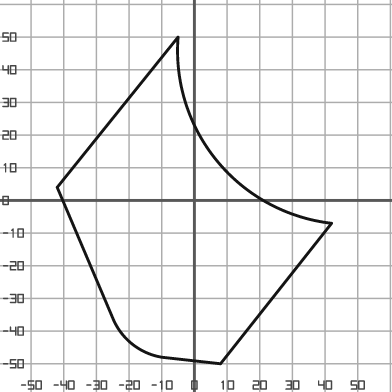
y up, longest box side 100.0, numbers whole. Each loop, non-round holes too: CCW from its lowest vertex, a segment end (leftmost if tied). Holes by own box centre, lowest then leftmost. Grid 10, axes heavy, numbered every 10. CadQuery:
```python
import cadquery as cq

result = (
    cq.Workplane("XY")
    .moveTo(8.0, -50.0)
    .lineTo(42.0, -7.0)
    .threePointArc((7.0, 12.0), (-5.0, 50.0))
    .lineTo(-42.0, 4.0)
    .lineTo(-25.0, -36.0)
    .threePointArc((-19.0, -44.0), (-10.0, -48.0))
    .close()
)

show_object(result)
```